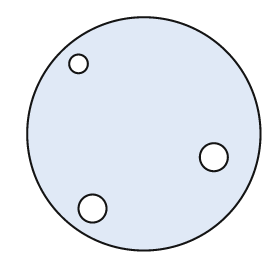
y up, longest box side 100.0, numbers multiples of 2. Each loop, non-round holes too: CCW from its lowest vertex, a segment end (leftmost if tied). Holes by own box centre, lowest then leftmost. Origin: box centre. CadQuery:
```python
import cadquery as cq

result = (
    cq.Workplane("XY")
    .moveTo(0.0, 0.0)
    .circle(50.0)
    .moveTo(-22.0, -32.0)
    .circle(6.0)
    .moveTo(30.0, -10.0)
    .circle(6.0)
    .moveTo(-28.0, 30.0)
    .circle(4.0)
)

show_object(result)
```